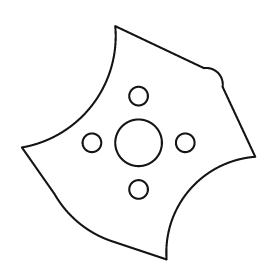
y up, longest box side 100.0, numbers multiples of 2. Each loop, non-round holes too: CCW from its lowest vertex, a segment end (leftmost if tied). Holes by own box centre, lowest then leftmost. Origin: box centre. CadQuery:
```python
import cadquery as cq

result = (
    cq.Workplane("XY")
    .moveTo(12.0, -50.0)
    .threePointArc((22.0, -20.0), (50.0, -6.0))
    .lineTo(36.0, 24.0)
    .threePointArc((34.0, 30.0), (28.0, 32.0))
    .lineTo(-10.0, 50.0)
    .threePointArc((-20.0, 16.0), (-50.0, -2.0))
    .lineTo(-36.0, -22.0)
    .threePointArc((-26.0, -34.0), (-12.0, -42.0))
    .close()
    .moveTo(0.0, -20.0)
    .circle(4.0)
    .moveTo(-20.0, 0.0)
    .circle(4.0)
    .moveTo(0.0, 0.0)
    .circle(10.0)
    .moveTo(20.0, 0.0)
    .circle(4.0)
    .moveTo(0.0, 20.0)
    .circle(4.0)
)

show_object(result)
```